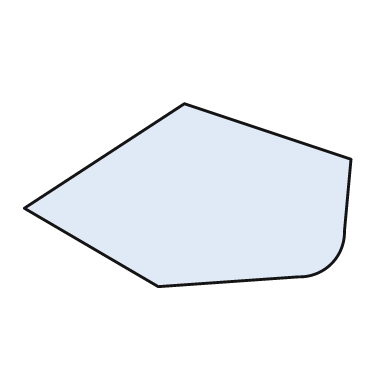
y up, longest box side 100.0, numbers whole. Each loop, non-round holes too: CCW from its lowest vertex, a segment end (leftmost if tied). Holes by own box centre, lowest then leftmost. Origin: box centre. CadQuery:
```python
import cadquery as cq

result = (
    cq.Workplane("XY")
    .moveTo(-9.0, -28.0)
    .lineTo(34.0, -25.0)
    .threePointArc((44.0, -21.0), (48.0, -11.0))
    .lineTo(50.0, 11.0)
    .lineTo(-1.0, 28.0)
    .lineTo(-50.0, -4.0)
    .close()
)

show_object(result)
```